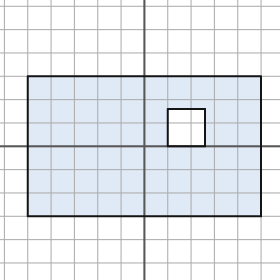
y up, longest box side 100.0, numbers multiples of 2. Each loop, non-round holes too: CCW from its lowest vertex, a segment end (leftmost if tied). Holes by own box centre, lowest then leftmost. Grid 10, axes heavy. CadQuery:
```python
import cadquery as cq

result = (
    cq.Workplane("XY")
    .moveTo(-50.0, -30.0)
    .lineTo(50.0, -30.0)
    .lineTo(50.0, 30.0)
    .lineTo(-50.0, 30.0)
    .close()
    .moveTo(10.0, 0.0)
    .lineTo(26.0, 0.0)
    .lineTo(26.0, 16.0)
    .lineTo(10.0, 16.0)
    .close()
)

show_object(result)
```